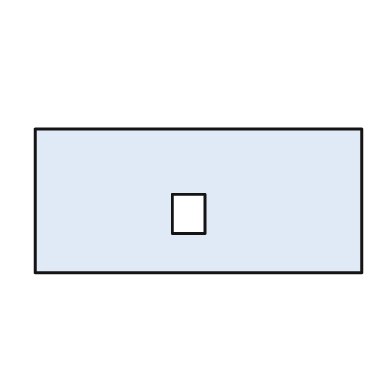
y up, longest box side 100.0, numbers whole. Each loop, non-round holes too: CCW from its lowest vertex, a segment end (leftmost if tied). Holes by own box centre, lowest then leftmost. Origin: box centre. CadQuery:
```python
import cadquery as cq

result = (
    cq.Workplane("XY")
    .moveTo(-50.0, -22.0)
    .lineTo(50.0, -22.0)
    .lineTo(50.0, 22.0)
    .lineTo(-50.0, 22.0)
    .close()
    .moveTo(-8.0, -10.0)
    .lineTo(2.0, -10.0)
    .lineTo(2.0, 2.0)
    .lineTo(-8.0, 2.0)
    .close()
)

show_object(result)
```